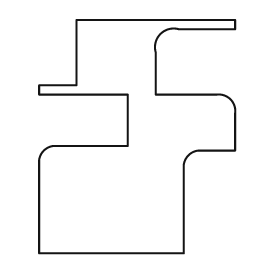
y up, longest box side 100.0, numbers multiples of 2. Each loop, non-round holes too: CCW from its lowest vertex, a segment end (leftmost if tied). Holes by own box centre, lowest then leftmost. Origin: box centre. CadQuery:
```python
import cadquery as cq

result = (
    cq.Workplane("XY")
    .moveTo(-42.0, -50.0)
    .lineTo(20.0, -50.0)
    .lineTo(20.0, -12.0)
    .threePointArc((22.0, -8.0), (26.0, -6.0))
    .lineTo(42.0, -6.0)
    .lineTo(42.0, 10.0)
    .threePointArc((40.0, 16.0), (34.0, 18.0))
    .lineTo(8.0, 18.0)
    .lineTo(8.0, 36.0)
    .threePointArc((10.0, 44.0), (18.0, 46.0))
    .lineTo(42.0, 46.0)
    .lineTo(42.0, 50.0)
    .lineTo(-26.0, 50.0)
    .lineTo(-26.0, 22.0)
    .lineTo(-42.0, 22.0)
    .lineTo(-42.0, 18.0)
    .lineTo(-4.0, 18.0)
    .lineTo(-4.0, -4.0)
    .lineTo(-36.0, -4.0)
    .threePointArc((-40.0, -6.0), (-42.0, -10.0))
    .close()
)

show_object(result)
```